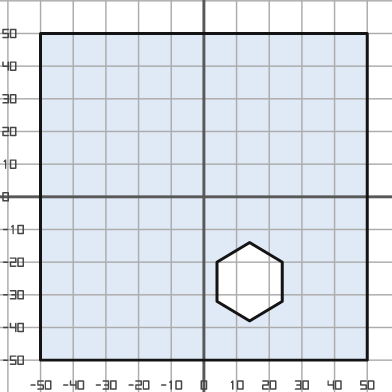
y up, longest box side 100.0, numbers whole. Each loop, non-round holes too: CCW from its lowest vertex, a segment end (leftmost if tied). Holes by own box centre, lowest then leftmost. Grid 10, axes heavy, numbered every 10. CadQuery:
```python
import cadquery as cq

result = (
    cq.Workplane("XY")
    .moveTo(-50.0, -50.0)
    .lineTo(50.0, -50.0)
    .lineTo(50.0, 50.0)
    .lineTo(-50.0, 50.0)
    .close()
    .moveTo(14.0, -38.0)
    .lineTo(24.0, -32.0)
    .lineTo(24.0, -20.0)
    .lineTo(14.0, -14.0)
    .lineTo(4.0, -20.0)
    .lineTo(4.0, -32.0)
    .close()
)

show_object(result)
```